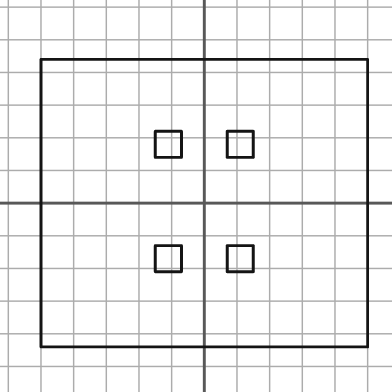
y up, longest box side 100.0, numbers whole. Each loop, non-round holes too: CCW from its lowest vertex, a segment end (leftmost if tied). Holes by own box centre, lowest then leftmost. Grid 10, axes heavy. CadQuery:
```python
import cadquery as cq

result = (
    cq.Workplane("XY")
    .moveTo(-50.0, -44.0)
    .lineTo(50.0, -44.0)
    .lineTo(50.0, 44.0)
    .lineTo(-50.0, 44.0)
    .close()
    .moveTo(-15.0, -21.0)
    .lineTo(-7.0, -21.0)
    .lineTo(-7.0, -13.0)
    .lineTo(-15.0, -13.0)
    .close()
    .moveTo(7.0, -21.0)
    .lineTo(15.0, -21.0)
    .lineTo(15.0, -13.0)
    .lineTo(7.0, -13.0)
    .close()
    .moveTo(-15.0, 14.0)
    .lineTo(-7.0, 14.0)
    .lineTo(-7.0, 22.0)
    .lineTo(-15.0, 22.0)
    .close()
    .moveTo(7.0, 14.0)
    .lineTo(15.0, 14.0)
    .lineTo(15.0, 22.0)
    .lineTo(7.0, 22.0)
    .close()
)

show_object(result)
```